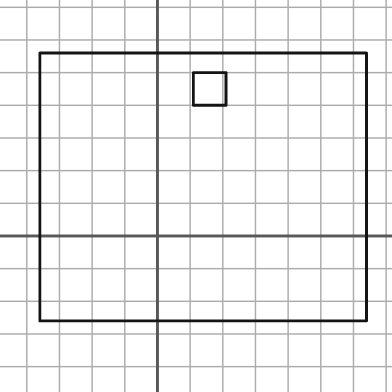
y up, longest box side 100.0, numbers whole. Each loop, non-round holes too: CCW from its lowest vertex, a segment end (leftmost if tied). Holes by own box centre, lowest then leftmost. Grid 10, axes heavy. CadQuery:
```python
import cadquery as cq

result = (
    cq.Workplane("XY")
    .moveTo(-36.0, -26.0)
    .lineTo(64.0, -26.0)
    .lineTo(64.0, 56.0)
    .lineTo(-36.0, 56.0)
    .close()
    .moveTo(11.0, 40.0)
    .lineTo(21.0, 40.0)
    .lineTo(21.0, 50.0)
    .lineTo(11.0, 50.0)
    .close()
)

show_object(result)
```